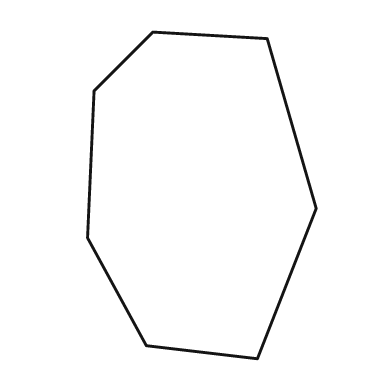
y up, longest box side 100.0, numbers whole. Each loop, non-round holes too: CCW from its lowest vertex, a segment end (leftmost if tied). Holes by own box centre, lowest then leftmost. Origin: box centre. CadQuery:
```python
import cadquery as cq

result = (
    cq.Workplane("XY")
    .moveTo(17.0, -50.0)
    .lineTo(35.0, -4.0)
    .lineTo(20.0, 48.0)
    .lineTo(-15.0, 50.0)
    .lineTo(-33.0, 32.0)
    .lineTo(-35.0, -13.0)
    .lineTo(-17.0, -46.0)
    .close()
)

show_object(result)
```